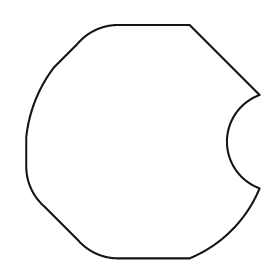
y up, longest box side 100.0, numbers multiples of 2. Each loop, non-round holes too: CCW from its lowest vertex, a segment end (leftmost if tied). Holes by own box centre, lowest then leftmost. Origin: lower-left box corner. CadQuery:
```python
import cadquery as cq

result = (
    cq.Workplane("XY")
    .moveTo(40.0, 0.0)
    .lineTo(70.0, 0.0)
    .threePointArc((88.0, 12.0), (100.0, 30.0))
    .threePointArc((86.0, 50.0), (100.0, 70.0))
    .lineTo(70.0, 100.0)
    .lineTo(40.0, 100.0)
    .threePointArc((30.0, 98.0), (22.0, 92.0))
    .lineTo(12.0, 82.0)
    .threePointArc((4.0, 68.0), (0.0, 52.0))
    .lineTo(0.0, 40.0)
    .threePointArc((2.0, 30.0), (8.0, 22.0))
    .lineTo(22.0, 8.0)
    .threePointArc((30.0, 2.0), (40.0, 0.0))
    .close()
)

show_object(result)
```